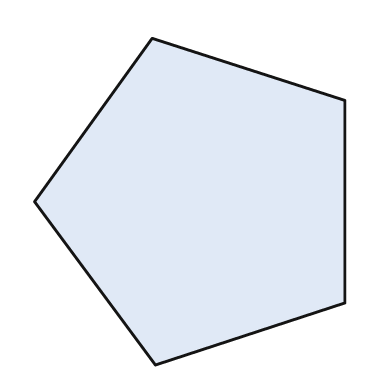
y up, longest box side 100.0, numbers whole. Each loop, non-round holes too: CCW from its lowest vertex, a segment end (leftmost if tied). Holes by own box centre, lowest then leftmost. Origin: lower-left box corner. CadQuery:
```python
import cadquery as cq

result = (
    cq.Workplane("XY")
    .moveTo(37.0, 0.0)
    .lineTo(95.0, 19.0)
    .lineTo(95.0, 81.0)
    .lineTo(36.0, 100.0)
    .lineTo(0.0, 50.0)
    .close()
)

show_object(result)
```